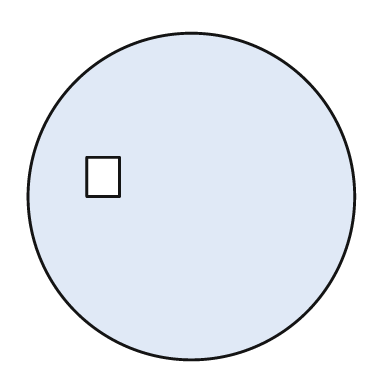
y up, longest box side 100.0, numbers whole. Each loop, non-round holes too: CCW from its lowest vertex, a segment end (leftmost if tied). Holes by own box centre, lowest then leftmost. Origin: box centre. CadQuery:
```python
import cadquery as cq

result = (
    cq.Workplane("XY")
    .moveTo(0.0, 0.0)
    .circle(50.0)
    .moveTo(-32.0, 0.0)
    .lineTo(-22.0, 0.0)
    .lineTo(-22.0, 12.0)
    .lineTo(-32.0, 12.0)
    .close()
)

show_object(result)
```